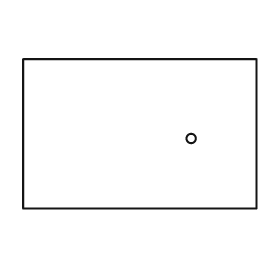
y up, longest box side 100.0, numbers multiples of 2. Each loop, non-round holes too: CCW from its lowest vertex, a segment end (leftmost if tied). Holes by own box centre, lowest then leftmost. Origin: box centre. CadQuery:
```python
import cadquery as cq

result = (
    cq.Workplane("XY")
    .moveTo(-50.0, -32.0)
    .lineTo(50.0, -32.0)
    .lineTo(50.0, 32.0)
    .lineTo(-50.0, 32.0)
    .close()
    .moveTo(22.0, -2.0)
    .circle(2.0)
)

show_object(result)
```